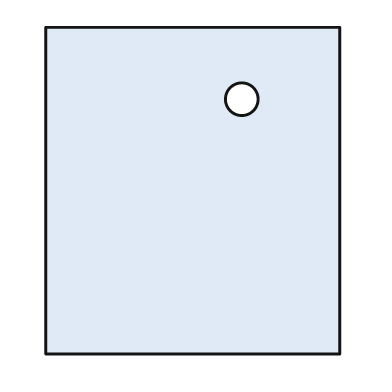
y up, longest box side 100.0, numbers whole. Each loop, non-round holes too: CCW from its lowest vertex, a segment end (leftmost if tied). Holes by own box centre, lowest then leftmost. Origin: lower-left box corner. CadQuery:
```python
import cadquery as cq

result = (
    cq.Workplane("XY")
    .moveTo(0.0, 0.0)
    .lineTo(90.0, 0.0)
    .lineTo(90.0, 100.0)
    .lineTo(0.0, 100.0)
    .close()
    .moveTo(60.0, 78.0)
    .circle(5.0)
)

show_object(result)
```